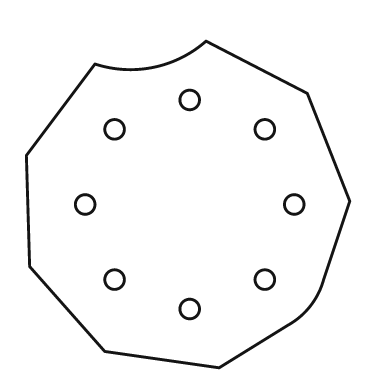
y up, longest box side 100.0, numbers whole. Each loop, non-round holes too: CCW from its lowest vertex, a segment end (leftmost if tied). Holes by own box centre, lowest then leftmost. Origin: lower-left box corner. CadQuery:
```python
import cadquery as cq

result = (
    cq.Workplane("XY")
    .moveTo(59.0, 0.0)
    .lineTo(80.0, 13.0)
    .threePointArc((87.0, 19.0), (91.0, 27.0))
    .lineTo(99.0, 51.0)
    .lineTo(86.0, 84.0)
    .lineTo(55.0, 100.0)
    .threePointArc((39.0, 92.0), (21.0, 93.0))
    .lineTo(0.0, 65.0)
    .lineTo(1.0, 31.0)
    .lineTo(24.0, 5.0)
    .close()
    .moveTo(50.0, 18.0)
    .circle(3.0)
    .moveTo(27.0, 27.0)
    .circle(3.0)
    .moveTo(73.0, 27.0)
    .circle(3.0)
    .moveTo(18.0, 50.0)
    .circle(3.0)
    .moveTo(82.0, 50.0)
    .circle(3.0)
    .moveTo(27.0, 73.0)
    .circle(3.0)
    .moveTo(73.0, 73.0)
    .circle(3.0)
    .moveTo(50.0, 82.0)
    .circle(3.0)
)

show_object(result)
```